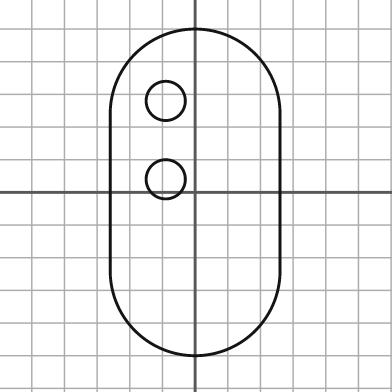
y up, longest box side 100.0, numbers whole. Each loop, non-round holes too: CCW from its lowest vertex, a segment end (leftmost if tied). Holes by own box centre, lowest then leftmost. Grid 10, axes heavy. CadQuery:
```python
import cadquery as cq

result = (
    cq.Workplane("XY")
    .moveTo(-26.0, -24.0)
    .threePointArc((0.0, -50.0), (26.0, -24.0))
    .lineTo(26.0, 24.0)
    .threePointArc((0.0, 50.0), (-26.0, 24.0))
    .close()
    .moveTo(-9.0, 4.0)
    .circle(6.0)
    .moveTo(-9.0, 28.0)
    .circle(6.0)
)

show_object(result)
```